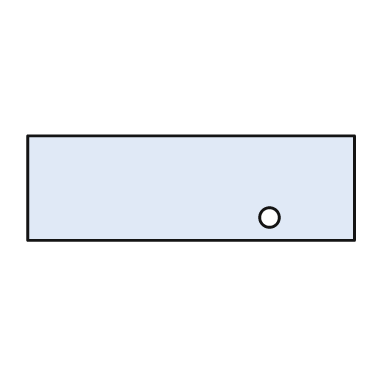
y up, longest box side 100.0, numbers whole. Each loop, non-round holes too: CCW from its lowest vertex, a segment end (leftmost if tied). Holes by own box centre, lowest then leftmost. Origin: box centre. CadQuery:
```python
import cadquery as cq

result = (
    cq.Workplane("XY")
    .moveTo(-50.0, -16.0)
    .lineTo(50.0, -16.0)
    .lineTo(50.0, 16.0)
    .lineTo(-50.0, 16.0)
    .close()
    .moveTo(24.0, -9.0)
    .circle(3.0)
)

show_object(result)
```